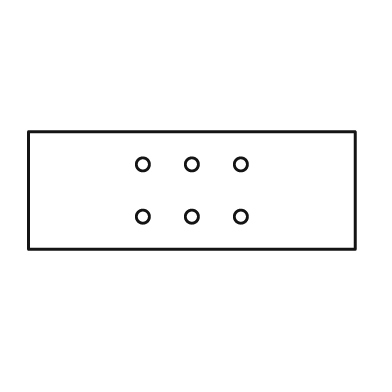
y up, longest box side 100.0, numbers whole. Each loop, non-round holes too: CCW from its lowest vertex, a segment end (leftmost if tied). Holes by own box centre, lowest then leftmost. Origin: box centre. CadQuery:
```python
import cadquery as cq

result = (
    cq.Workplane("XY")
    .moveTo(-50.0, -18.0)
    .lineTo(50.0, -18.0)
    .lineTo(50.0, 18.0)
    .lineTo(-50.0, 18.0)
    .close()
    .moveTo(-15.0, -8.0)
    .circle(2.0)
    .moveTo(0.0, -8.0)
    .circle(2.0)
    .moveTo(15.0, -8.0)
    .circle(2.0)
    .moveTo(-15.0, 8.0)
    .circle(2.0)
    .moveTo(0.0, 8.0)
    .circle(2.0)
    .moveTo(15.0, 8.0)
    .circle(2.0)
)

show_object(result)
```